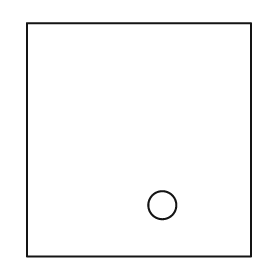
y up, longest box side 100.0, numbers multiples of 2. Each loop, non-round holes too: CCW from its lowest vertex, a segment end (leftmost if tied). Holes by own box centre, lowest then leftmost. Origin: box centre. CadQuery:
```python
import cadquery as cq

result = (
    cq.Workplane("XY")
    .moveTo(-48.0, -50.0)
    .lineTo(48.0, -50.0)
    .lineTo(48.0, 50.0)
    .lineTo(-48.0, 50.0)
    .close()
    .moveTo(10.0, -28.0)
    .circle(6.0)
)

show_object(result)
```